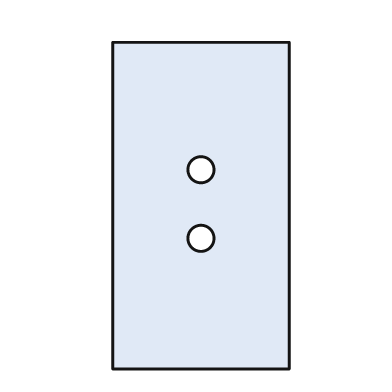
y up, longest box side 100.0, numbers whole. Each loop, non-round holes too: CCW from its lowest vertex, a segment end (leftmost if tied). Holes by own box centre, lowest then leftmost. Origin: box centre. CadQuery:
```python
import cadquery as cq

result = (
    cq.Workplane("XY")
    .moveTo(-27.0, -50.0)
    .lineTo(27.0, -50.0)
    .lineTo(27.0, 50.0)
    .lineTo(-27.0, 50.0)
    .close()
    .moveTo(0.0, -10.0)
    .circle(4.0)
    .moveTo(0.0, 11.0)
    .circle(4.0)
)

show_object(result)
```